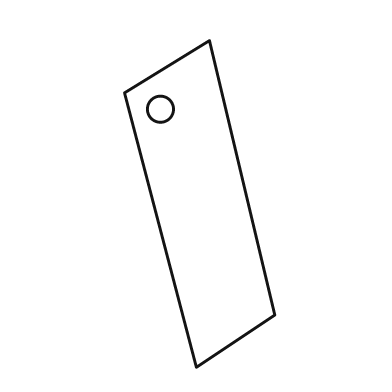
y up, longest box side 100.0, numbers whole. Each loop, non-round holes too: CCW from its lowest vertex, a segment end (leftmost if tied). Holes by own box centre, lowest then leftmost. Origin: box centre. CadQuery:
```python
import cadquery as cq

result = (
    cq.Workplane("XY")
    .moveTo(-1.0, -50.0)
    .lineTo(23.0, -34.0)
    .lineTo(3.0, 50.0)
    .lineTo(-23.0, 34.0)
    .close()
    .moveTo(-12.0, 29.0)
    .circle(4.0)
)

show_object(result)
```